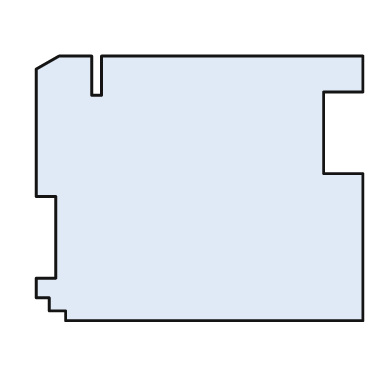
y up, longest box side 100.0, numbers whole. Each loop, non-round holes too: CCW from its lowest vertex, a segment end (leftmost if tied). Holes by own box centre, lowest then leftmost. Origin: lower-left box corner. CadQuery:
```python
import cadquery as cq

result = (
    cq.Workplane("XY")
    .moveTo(9.0, 0.0)
    .lineTo(100.0, 0.0)
    .lineTo(100.0, 45.0)
    .lineTo(88.0, 45.0)
    .lineTo(88.0, 70.0)
    .lineTo(100.0, 70.0)
    .lineTo(100.0, 81.0)
    .lineTo(20.0, 81.0)
    .lineTo(20.0, 69.0)
    .lineTo(17.0, 69.0)
    .lineTo(17.0, 81.0)
    .lineTo(7.0, 81.0)
    .lineTo(0.0, 77.0)
    .lineTo(0.0, 38.0)
    .lineTo(6.0, 38.0)
    .lineTo(6.0, 13.0)
    .lineTo(0.0, 13.0)
    .lineTo(0.0, 7.0)
    .lineTo(4.0, 7.0)
    .lineTo(4.0, 3.0)
    .lineTo(9.0, 3.0)
    .close()
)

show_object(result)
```